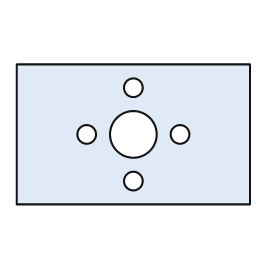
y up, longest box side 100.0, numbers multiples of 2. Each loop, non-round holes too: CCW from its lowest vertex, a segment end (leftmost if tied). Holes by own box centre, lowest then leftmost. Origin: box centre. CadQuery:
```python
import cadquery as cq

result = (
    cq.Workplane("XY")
    .moveTo(-50.0, -30.0)
    .lineTo(50.0, -30.0)
    .lineTo(50.0, 30.0)
    .lineTo(-50.0, 30.0)
    .close()
    .moveTo(0.0, -20.0)
    .circle(4.0)
    .moveTo(-20.0, 0.0)
    .circle(4.0)
    .moveTo(0.0, 0.0)
    .circle(10.0)
    .moveTo(20.0, 0.0)
    .circle(4.0)
    .moveTo(0.0, 20.0)
    .circle(4.0)
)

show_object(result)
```